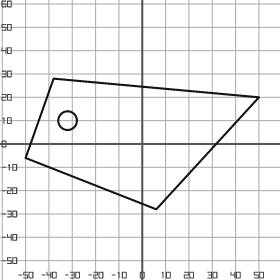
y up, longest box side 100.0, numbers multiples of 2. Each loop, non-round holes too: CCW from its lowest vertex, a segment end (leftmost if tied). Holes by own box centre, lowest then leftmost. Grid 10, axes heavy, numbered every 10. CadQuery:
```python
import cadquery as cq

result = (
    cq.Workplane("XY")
    .moveTo(6.0, -28.0)
    .lineTo(50.0, 20.0)
    .lineTo(-38.0, 28.0)
    .lineTo(-50.0, -6.0)
    .close()
    .moveTo(-32.0, 10.0)
    .circle(4.0)
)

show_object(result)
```